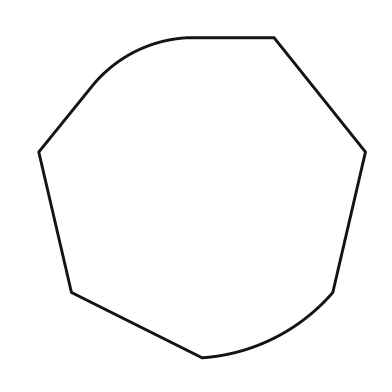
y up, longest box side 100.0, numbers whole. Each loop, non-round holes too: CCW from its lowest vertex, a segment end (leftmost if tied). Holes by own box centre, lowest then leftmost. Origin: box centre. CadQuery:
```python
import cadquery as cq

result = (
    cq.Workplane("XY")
    .moveTo(0.0, -49.0)
    .threePointArc((22.0, -43.0), (40.0, -29.0))
    .lineTo(50.0, 14.0)
    .lineTo(22.0, 49.0)
    .lineTo(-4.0, 49.0)
    .threePointArc((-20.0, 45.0), (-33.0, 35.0))
    .lineTo(-50.0, 14.0)
    .lineTo(-40.0, -29.0)
    .close()
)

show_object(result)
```